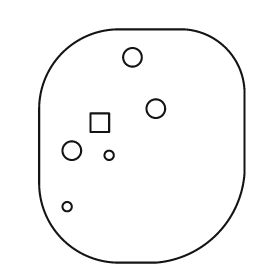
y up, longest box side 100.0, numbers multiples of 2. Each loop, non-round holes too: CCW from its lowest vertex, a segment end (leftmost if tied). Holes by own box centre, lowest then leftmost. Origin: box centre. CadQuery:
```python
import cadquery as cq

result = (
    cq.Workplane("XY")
    .moveTo(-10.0, -50.0)
    .lineTo(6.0, -50.0)
    .threePointArc((32.0, -38.0), (44.0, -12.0))
    .lineTo(44.0, 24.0)
    .threePointArc((36.0, 42.0), (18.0, 50.0))
    .lineTo(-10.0, 50.0)
    .threePointArc((-34.0, 40.0), (-44.0, 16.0))
    .lineTo(-44.0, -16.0)
    .threePointArc((-34.0, -40.0), (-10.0, -50.0))
    .close()
    .moveTo(-32.0, -26.0)
    .circle(2.0)
    .moveTo(-14.0, -4.0)
    .circle(2.0)
    .moveTo(-30.0, -2.0)
    .circle(4.0)
    .moveTo(-22.0, 6.0)
    .lineTo(-14.0, 6.0)
    .lineTo(-14.0, 14.0)
    .lineTo(-22.0, 14.0)
    .close()
    .moveTo(6.0, 16.0)
    .circle(4.0)
    .moveTo(-4.0, 38.0)
    .circle(4.0)
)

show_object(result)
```